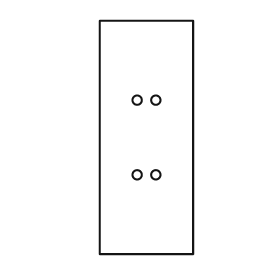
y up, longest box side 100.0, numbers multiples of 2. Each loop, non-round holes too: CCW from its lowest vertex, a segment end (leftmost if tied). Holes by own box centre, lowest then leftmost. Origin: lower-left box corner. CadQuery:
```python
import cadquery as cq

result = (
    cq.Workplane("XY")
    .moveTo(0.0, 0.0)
    .lineTo(40.0, 0.0)
    .lineTo(40.0, 100.0)
    .lineTo(0.0, 100.0)
    .close()
    .moveTo(16.0, 34.0)
    .circle(2.0)
    .moveTo(24.0, 34.0)
    .circle(2.0)
    .moveTo(16.0, 66.0)
    .circle(2.0)
    .moveTo(24.0, 66.0)
    .circle(2.0)
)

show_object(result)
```